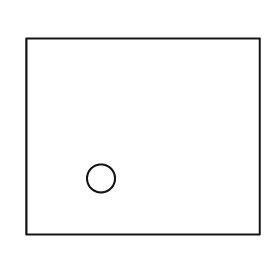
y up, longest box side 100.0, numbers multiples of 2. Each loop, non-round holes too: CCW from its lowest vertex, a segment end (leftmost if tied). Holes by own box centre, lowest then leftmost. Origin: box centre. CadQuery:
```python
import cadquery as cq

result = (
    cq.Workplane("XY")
    .moveTo(-50.0, -42.0)
    .lineTo(50.0, -42.0)
    .lineTo(50.0, 42.0)
    .lineTo(-50.0, 42.0)
    .close()
    .moveTo(-18.0, -18.0)
    .circle(6.0)
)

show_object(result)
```